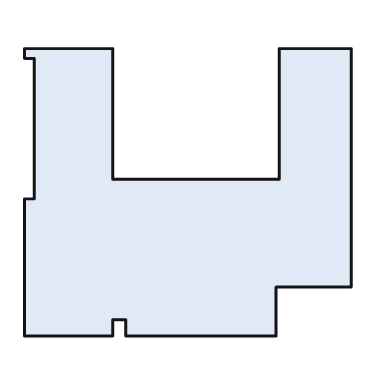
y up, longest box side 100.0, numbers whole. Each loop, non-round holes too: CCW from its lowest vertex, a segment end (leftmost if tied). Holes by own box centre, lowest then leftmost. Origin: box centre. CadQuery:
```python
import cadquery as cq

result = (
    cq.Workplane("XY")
    .moveTo(-50.0, -44.0)
    .lineTo(-23.0, -44.0)
    .lineTo(-23.0, -39.0)
    .lineTo(-19.0, -39.0)
    .lineTo(-19.0, -44.0)
    .lineTo(27.0, -44.0)
    .lineTo(27.0, -29.0)
    .lineTo(50.0, -29.0)
    .lineTo(50.0, 44.0)
    .lineTo(28.0, 44.0)
    .lineTo(28.0, 4.0)
    .lineTo(-23.0, 4.0)
    .lineTo(-23.0, 44.0)
    .lineTo(-50.0, 44.0)
    .lineTo(-50.0, 41.0)
    .lineTo(-47.0, 41.0)
    .lineTo(-47.0, -2.0)
    .lineTo(-50.0, -2.0)
    .close()
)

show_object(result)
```